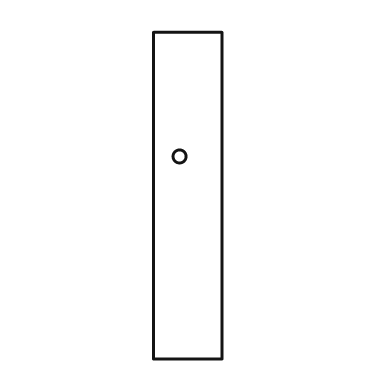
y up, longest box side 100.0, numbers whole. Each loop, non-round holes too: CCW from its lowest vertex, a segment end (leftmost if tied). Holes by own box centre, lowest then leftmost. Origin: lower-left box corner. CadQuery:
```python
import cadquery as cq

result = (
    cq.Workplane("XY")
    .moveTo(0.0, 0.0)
    .lineTo(21.0, 0.0)
    .lineTo(21.0, 100.0)
    .lineTo(0.0, 100.0)
    .close()
    .moveTo(8.0, 62.0)
    .circle(2.0)
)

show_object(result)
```